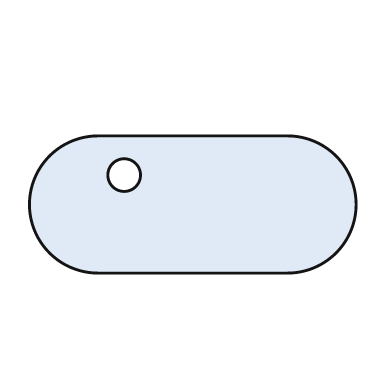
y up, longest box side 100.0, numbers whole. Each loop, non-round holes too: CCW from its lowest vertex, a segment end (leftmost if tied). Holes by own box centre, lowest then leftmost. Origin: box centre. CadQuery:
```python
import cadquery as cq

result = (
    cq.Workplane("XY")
    .moveTo(-29.0, -21.0)
    .lineTo(29.0, -21.0)
    .threePointArc((50.0, 0.0), (29.0, 21.0))
    .lineTo(-29.0, 21.0)
    .threePointArc((-50.0, 0.0), (-29.0, -21.0))
    .close()
    .moveTo(-21.0, 9.0)
    .circle(5.0)
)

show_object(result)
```